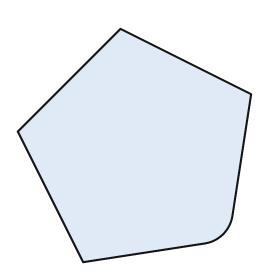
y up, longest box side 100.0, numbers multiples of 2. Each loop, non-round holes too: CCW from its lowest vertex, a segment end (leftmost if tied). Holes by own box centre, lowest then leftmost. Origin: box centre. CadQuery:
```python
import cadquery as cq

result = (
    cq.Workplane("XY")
    .moveTo(-22.0, -50.0)
    .lineTo(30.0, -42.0)
    .threePointArc((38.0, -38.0), (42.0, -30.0))
    .lineTo(50.0, 22.0)
    .lineTo(-6.0, 50.0)
    .lineTo(-50.0, 6.0)
    .close()
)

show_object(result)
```